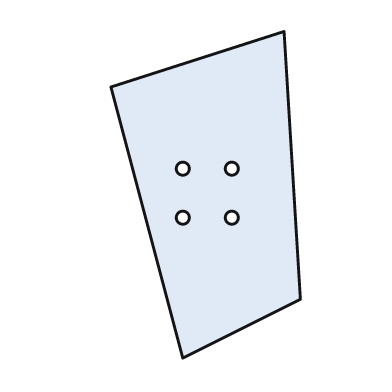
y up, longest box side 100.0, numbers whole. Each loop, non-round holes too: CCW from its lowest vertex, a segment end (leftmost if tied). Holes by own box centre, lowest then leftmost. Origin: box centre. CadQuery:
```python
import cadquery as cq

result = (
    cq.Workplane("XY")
    .moveTo(-7.0, -50.0)
    .lineTo(29.0, -32.0)
    .lineTo(24.0, 50.0)
    .lineTo(-29.0, 33.0)
    .close()
    .moveTo(-7.0, -7.0)
    .circle(2.0)
    .moveTo(8.0, -7.0)
    .circle(2.0)
    .moveTo(-7.0, 8.0)
    .circle(2.0)
    .moveTo(8.0, 8.0)
    .circle(2.0)
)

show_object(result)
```